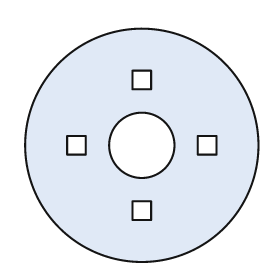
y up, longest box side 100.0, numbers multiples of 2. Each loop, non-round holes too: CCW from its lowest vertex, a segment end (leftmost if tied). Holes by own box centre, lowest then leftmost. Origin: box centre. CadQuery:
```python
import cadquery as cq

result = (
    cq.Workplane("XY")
    .moveTo(0.0, 0.0)
    .circle(50.0)
    .moveTo(-4.0, -32.0)
    .lineTo(4.0, -32.0)
    .lineTo(4.0, -24.0)
    .lineTo(-4.0, -24.0)
    .close()
    .moveTo(-32.0, -4.0)
    .lineTo(-24.0, -4.0)
    .lineTo(-24.0, 4.0)
    .lineTo(-32.0, 4.0)
    .close()
    .moveTo(0.0, 0.0)
    .circle(14.0)
    .moveTo(24.0, -4.0)
    .lineTo(32.0, -4.0)
    .lineTo(32.0, 4.0)
    .lineTo(24.0, 4.0)
    .close()
    .moveTo(-4.0, 24.0)
    .lineTo(4.0, 24.0)
    .lineTo(4.0, 32.0)
    .lineTo(-4.0, 32.0)
    .close()
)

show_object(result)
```